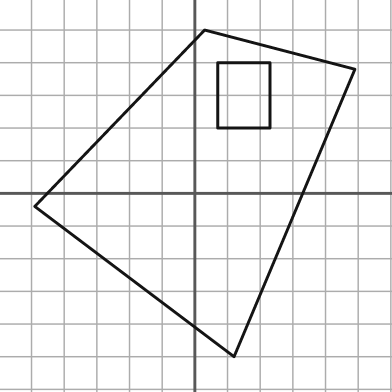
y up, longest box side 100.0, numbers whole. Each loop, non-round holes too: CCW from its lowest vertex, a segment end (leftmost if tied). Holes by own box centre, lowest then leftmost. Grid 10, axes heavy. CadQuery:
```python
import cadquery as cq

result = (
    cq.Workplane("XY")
    .moveTo(12.0, -50.0)
    .lineTo(49.0, 38.0)
    .lineTo(3.0, 50.0)
    .lineTo(-49.0, -4.0)
    .close()
    .moveTo(7.0, 20.0)
    .lineTo(23.0, 20.0)
    .lineTo(23.0, 40.0)
    .lineTo(7.0, 40.0)
    .close()
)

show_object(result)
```